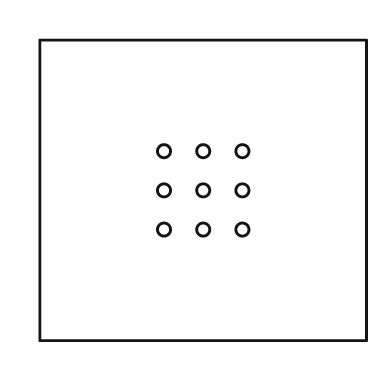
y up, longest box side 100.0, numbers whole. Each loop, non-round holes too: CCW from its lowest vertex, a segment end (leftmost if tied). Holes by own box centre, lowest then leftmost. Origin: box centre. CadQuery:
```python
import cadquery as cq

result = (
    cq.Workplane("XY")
    .moveTo(-50.0, -46.0)
    .lineTo(50.0, -46.0)
    .lineTo(50.0, 46.0)
    .lineTo(-50.0, 46.0)
    .close()
    .moveTo(-12.0, -12.0)
    .circle(2.0)
    .moveTo(0.0, -12.0)
    .circle(2.0)
    .moveTo(12.0, -12.0)
    .circle(2.0)
    .moveTo(-12.0, 0.0)
    .circle(2.0)
    .moveTo(0.0, 0.0)
    .circle(2.0)
    .moveTo(12.0, 0.0)
    .circle(2.0)
    .moveTo(-12.0, 12.0)
    .circle(2.0)
    .moveTo(0.0, 12.0)
    .circle(2.0)
    .moveTo(12.0, 12.0)
    .circle(2.0)
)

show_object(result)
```